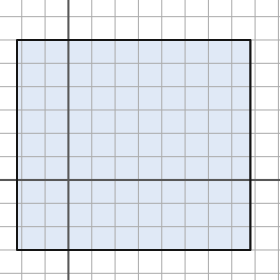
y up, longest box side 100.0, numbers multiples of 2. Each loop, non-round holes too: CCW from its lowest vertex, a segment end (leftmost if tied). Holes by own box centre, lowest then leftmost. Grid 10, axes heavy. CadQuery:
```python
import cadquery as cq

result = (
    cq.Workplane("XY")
    .moveTo(-22.0, -30.0)
    .lineTo(78.0, -30.0)
    .lineTo(78.0, 60.0)
    .lineTo(-22.0, 60.0)
    .close()
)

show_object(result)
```